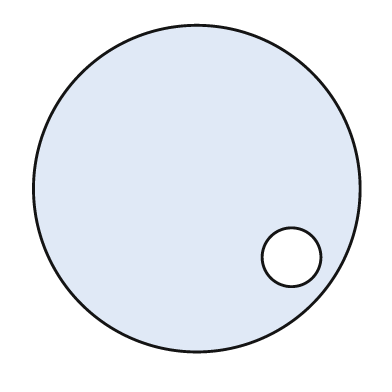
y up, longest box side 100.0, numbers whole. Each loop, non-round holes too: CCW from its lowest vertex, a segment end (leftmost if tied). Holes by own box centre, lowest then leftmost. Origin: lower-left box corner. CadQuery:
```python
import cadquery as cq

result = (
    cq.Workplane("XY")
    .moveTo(50.0, 50.0)
    .circle(50.0)
    .moveTo(79.0, 29.0)
    .circle(9.0)
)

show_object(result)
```